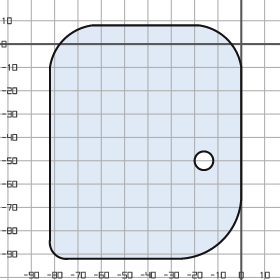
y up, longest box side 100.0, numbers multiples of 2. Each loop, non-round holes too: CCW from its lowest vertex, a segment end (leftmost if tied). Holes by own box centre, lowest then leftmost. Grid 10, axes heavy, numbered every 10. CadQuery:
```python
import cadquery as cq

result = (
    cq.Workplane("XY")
    .moveTo(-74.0, -92.0)
    .lineTo(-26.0, -92.0)
    .threePointArc((-8.0, -84.0), (0.0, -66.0))
    .lineTo(0.0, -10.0)
    .threePointArc((-6.0, 2.0), (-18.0, 8.0))
    .lineTo(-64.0, 8.0)
    .threePointArc((-76.0, 2.0), (-82.0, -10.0))
    .lineTo(-82.0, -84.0)
    .threePointArc((-80.0, -90.0), (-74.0, -92.0))
    .close()
    .moveTo(-16.0, -50.0)
    .circle(4.0)
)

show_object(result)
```